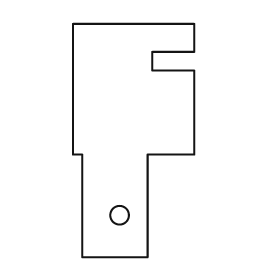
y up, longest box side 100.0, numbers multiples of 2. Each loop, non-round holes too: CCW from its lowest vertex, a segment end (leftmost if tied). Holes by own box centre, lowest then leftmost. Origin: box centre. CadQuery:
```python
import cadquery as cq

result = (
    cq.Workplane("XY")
    .moveTo(-22.0, -50.0)
    .lineTo(6.0, -50.0)
    .lineTo(6.0, -6.0)
    .lineTo(26.0, -6.0)
    .lineTo(26.0, 30.0)
    .lineTo(8.0, 30.0)
    .lineTo(8.0, 38.0)
    .lineTo(26.0, 38.0)
    .lineTo(26.0, 50.0)
    .lineTo(-26.0, 50.0)
    .lineTo(-26.0, -6.0)
    .lineTo(-22.0, -6.0)
    .close()
    .moveTo(-6.0, -32.0)
    .circle(4.0)
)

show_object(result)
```